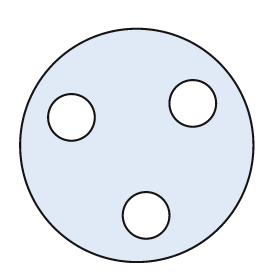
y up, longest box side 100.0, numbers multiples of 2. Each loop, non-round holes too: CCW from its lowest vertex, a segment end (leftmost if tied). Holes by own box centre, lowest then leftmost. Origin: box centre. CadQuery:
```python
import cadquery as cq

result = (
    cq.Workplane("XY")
    .moveTo(0.0, 0.0)
    .circle(50.0)
    .moveTo(4.0, -30.0)
    .circle(10.0)
    .moveTo(-28.0, 12.0)
    .circle(10.0)
    .moveTo(24.0, 18.0)
    .circle(10.0)
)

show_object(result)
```